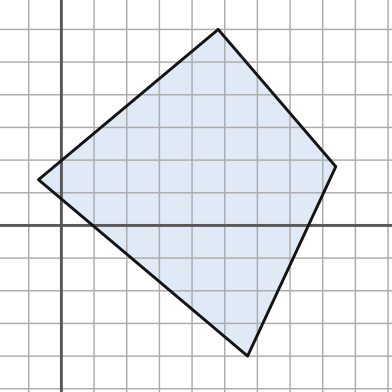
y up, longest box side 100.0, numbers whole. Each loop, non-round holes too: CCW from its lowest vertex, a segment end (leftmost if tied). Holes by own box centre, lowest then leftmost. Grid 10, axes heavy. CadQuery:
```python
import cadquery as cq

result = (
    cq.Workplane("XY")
    .moveTo(57.0, -40.0)
    .lineTo(84.0, 18.0)
    .lineTo(48.0, 60.0)
    .lineTo(-7.0, 14.0)
    .close()
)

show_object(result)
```